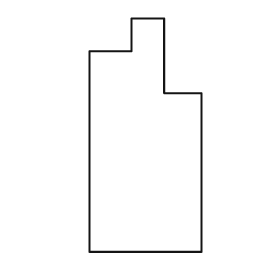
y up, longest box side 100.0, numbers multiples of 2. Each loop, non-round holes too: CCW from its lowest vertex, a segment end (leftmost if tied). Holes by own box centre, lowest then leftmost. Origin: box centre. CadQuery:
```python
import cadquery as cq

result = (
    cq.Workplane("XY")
    .moveTo(-24.0, -50.0)
    .lineTo(24.0, -50.0)
    .lineTo(24.0, 18.0)
    .lineTo(8.0, 18.0)
    .lineTo(8.0, 50.0)
    .lineTo(-6.0, 50.0)
    .lineTo(-6.0, 36.0)
    .lineTo(-24.0, 36.0)
    .close()
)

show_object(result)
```